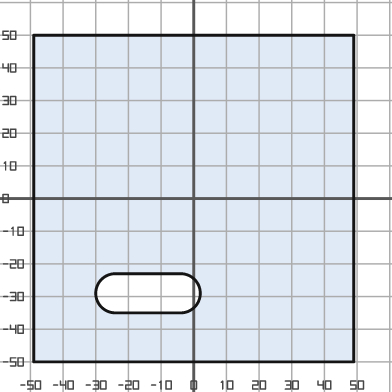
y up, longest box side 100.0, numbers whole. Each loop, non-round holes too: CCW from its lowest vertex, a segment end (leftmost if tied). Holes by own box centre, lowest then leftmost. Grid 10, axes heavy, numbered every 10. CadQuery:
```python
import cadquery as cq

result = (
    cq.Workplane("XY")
    .moveTo(-49.0, -50.0)
    .lineTo(49.0, -50.0)
    .lineTo(49.0, 50.0)
    .lineTo(-49.0, 50.0)
    .close()
    .moveTo(-24.0, -35.0)
    .lineTo(-4.0, -35.0)
    .threePointArc((2.0, -29.0), (-4.0, -23.0))
    .lineTo(-24.0, -23.0)
    .threePointArc((-30.0, -29.0), (-24.0, -35.0))
    .close()
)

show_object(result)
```